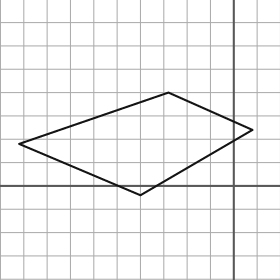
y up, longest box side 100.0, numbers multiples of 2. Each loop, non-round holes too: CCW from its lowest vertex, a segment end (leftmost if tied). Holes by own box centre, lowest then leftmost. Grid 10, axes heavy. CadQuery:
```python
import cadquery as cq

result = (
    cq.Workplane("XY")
    .moveTo(-40.0, -4.0)
    .lineTo(8.0, 24.0)
    .lineTo(-28.0, 40.0)
    .lineTo(-92.0, 18.0)
    .close()
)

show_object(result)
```